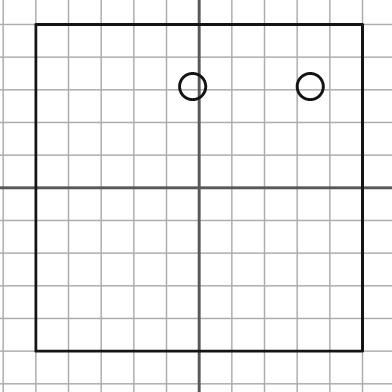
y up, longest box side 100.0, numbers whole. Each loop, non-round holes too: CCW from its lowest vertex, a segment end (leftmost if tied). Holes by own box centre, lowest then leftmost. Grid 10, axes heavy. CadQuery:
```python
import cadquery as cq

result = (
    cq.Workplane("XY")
    .moveTo(-50.0, -50.0)
    .lineTo(50.0, -50.0)
    .lineTo(50.0, 50.0)
    .lineTo(-50.0, 50.0)
    .close()
    .moveTo(-2.0, 31.0)
    .circle(4.0)
    .moveTo(34.0, 31.0)
    .circle(4.0)
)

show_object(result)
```